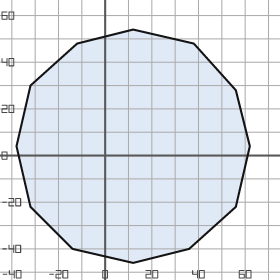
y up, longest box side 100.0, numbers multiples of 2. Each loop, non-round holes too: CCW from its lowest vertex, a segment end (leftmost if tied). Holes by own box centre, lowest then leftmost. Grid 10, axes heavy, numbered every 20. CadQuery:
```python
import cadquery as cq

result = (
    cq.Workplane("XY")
    .moveTo(12.0, -46.0)
    .lineTo(36.0, -40.0)
    .lineTo(56.0, -22.0)
    .lineTo(62.0, 4.0)
    .lineTo(56.0, 28.0)
    .lineTo(38.0, 48.0)
    .lineTo(12.0, 54.0)
    .lineTo(-12.0, 48.0)
    .lineTo(-32.0, 30.0)
    .lineTo(-38.0, 4.0)
    .lineTo(-32.0, -22.0)
    .lineTo(-14.0, -40.0)
    .close()
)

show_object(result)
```